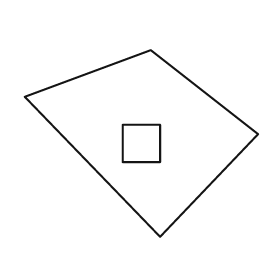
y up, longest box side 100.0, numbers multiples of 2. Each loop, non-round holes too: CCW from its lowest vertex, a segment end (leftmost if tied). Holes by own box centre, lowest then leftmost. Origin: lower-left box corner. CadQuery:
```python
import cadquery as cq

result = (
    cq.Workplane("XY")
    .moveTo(58.0, 0.0)
    .lineTo(100.0, 44.0)
    .lineTo(54.0, 80.0)
    .lineTo(0.0, 60.0)
    .close()
    .moveTo(42.0, 32.0)
    .lineTo(58.0, 32.0)
    .lineTo(58.0, 48.0)
    .lineTo(42.0, 48.0)
    .close()
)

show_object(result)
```